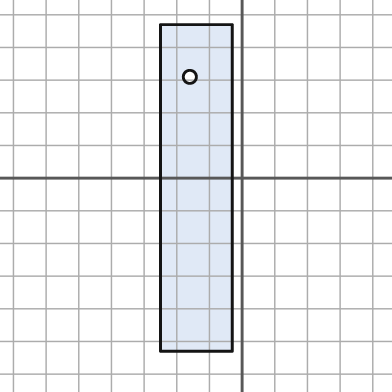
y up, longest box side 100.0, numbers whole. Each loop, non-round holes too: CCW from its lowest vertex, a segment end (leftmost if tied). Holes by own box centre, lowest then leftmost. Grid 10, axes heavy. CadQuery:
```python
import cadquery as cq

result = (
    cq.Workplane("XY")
    .moveTo(-25.0, -53.0)
    .lineTo(-3.0, -53.0)
    .lineTo(-3.0, 47.0)
    .lineTo(-25.0, 47.0)
    .close()
    .moveTo(-16.0, 31.0)
    .circle(2.0)
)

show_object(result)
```